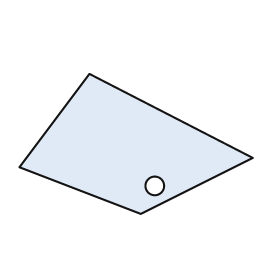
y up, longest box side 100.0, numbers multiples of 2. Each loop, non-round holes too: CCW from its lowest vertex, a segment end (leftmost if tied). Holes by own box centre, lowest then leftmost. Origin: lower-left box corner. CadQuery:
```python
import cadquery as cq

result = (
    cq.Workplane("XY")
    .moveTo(52.0, 0.0)
    .lineTo(100.0, 24.0)
    .lineTo(30.0, 60.0)
    .lineTo(0.0, 20.0)
    .close()
    .moveTo(58.0, 12.0)
    .circle(4.0)
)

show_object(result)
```